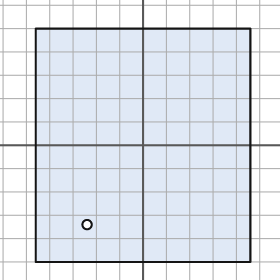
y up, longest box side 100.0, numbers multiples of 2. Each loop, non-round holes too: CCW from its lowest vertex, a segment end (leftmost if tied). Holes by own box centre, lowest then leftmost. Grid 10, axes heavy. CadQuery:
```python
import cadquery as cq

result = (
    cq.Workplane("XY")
    .moveTo(-46.0, -50.0)
    .lineTo(46.0, -50.0)
    .lineTo(46.0, 50.0)
    .lineTo(-46.0, 50.0)
    .close()
    .moveTo(-24.0, -34.0)
    .circle(2.0)
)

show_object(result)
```